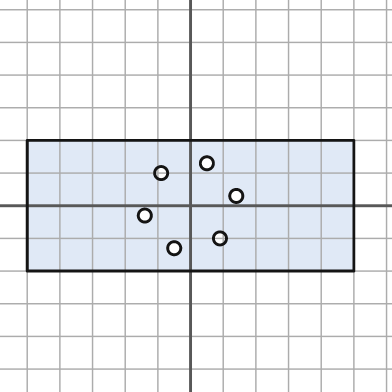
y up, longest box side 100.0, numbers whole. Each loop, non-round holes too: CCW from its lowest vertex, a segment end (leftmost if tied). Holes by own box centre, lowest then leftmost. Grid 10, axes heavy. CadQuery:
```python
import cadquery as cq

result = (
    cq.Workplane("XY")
    .moveTo(-50.0, -20.0)
    .lineTo(50.0, -20.0)
    .lineTo(50.0, 20.0)
    .lineTo(-50.0, 20.0)
    .close()
    .moveTo(-5.0, -13.0)
    .circle(2.0)
    .moveTo(9.0, -10.0)
    .circle(2.0)
    .moveTo(-14.0, -3.0)
    .circle(2.0)
    .moveTo(14.0, 3.0)
    .circle(2.0)
    .moveTo(-9.0, 10.0)
    .circle(2.0)
    .moveTo(5.0, 13.0)
    .circle(2.0)
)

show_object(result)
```